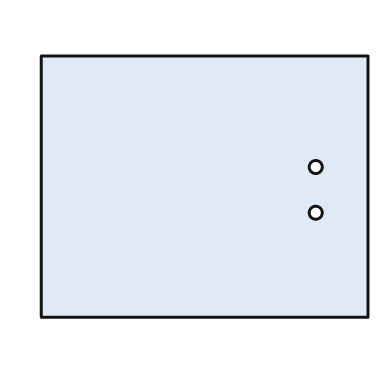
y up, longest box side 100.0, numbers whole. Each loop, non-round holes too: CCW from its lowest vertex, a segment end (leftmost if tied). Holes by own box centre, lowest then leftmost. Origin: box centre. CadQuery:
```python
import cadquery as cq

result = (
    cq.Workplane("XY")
    .moveTo(-50.0, -40.0)
    .lineTo(50.0, -40.0)
    .lineTo(50.0, 40.0)
    .lineTo(-50.0, 40.0)
    .close()
    .moveTo(34.0, -8.0)
    .circle(2.0)
    .moveTo(34.0, 6.0)
    .circle(2.0)
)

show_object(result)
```